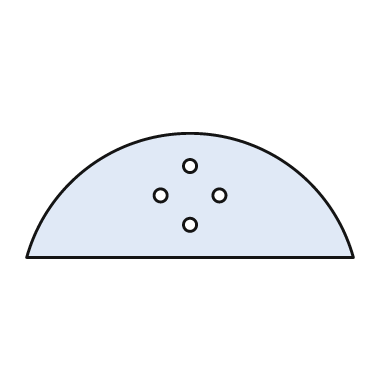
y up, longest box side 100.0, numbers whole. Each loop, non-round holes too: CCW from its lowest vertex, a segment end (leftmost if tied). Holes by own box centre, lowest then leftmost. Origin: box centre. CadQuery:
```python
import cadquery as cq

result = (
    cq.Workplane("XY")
    .moveTo(-50.0, -19.0)
    .lineTo(50.0, -19.0)
    .threePointArc((0.0, 19.0), (-50.0, -19.0))
    .close()
    .moveTo(0.0, -9.0)
    .circle(2.0)
    .moveTo(-9.0, 0.0)
    .circle(2.0)
    .moveTo(9.0, 0.0)
    .circle(2.0)
    .moveTo(0.0, 9.0)
    .circle(2.0)
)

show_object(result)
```